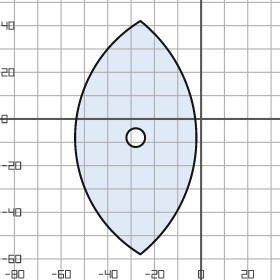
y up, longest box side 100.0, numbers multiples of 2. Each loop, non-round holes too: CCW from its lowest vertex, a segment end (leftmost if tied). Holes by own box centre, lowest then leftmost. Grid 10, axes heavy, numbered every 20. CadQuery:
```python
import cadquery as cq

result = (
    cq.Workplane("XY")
    .moveTo(-26.0, -58.0)
    .threePointArc((-2.0, -8.0), (-26.0, 42.0))
    .threePointArc((-54.0, -8.0), (-26.0, -58.0))
    .close()
    .moveTo(-28.0, -8.0)
    .circle(4.0)
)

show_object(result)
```